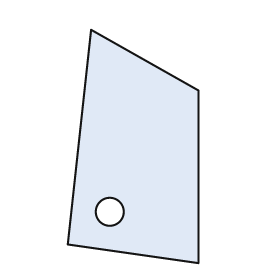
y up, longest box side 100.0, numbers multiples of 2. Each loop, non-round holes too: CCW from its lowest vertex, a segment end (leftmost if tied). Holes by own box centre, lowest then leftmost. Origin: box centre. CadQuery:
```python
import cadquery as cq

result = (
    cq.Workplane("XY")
    .moveTo(28.0, -50.0)
    .lineTo(28.0, 24.0)
    .lineTo(-18.0, 50.0)
    .lineTo(-28.0, -42.0)
    .close()
    .moveTo(-10.0, -28.0)
    .circle(6.0)
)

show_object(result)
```